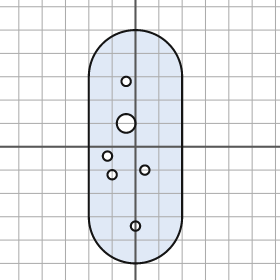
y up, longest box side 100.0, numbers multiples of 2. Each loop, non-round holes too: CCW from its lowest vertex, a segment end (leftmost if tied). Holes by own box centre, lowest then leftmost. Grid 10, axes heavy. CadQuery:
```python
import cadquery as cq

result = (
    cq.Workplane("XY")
    .moveTo(-20.0, -30.0)
    .threePointArc((0.0, -50.0), (20.0, -30.0))
    .lineTo(20.0, 30.0)
    .threePointArc((0.0, 50.0), (-20.0, 30.0))
    .close()
    .moveTo(0.0, -34.0)
    .circle(2.0)
    .moveTo(-10.0, -12.0)
    .circle(2.0)
    .moveTo(4.0, -10.0)
    .circle(2.0)
    .moveTo(-12.0, -4.0)
    .circle(2.0)
    .moveTo(-4.0, 10.0)
    .circle(4.0)
    .moveTo(-4.0, 28.0)
    .circle(2.0)
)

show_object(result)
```